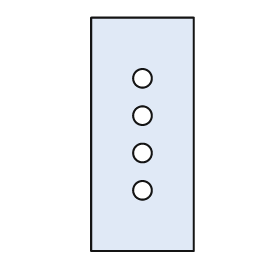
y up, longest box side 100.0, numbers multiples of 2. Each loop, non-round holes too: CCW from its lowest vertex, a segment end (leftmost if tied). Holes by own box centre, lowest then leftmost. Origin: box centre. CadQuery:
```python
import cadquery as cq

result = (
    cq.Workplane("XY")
    .moveTo(-22.0, -50.0)
    .lineTo(22.0, -50.0)
    .lineTo(22.0, 50.0)
    .lineTo(-22.0, 50.0)
    .close()
    .moveTo(0.0, -24.0)
    .circle(4.0)
    .moveTo(0.0, -8.0)
    .circle(4.0)
    .moveTo(0.0, 8.0)
    .circle(4.0)
    .moveTo(0.0, 24.0)
    .circle(4.0)
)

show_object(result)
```